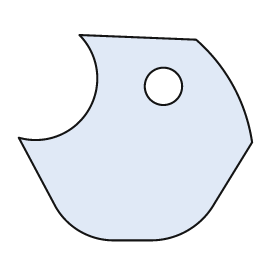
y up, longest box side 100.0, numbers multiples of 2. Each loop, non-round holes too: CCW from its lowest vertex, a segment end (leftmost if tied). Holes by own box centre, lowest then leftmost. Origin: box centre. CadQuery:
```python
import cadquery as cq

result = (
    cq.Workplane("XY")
    .moveTo(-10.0, -44.0)
    .lineTo(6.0, -44.0)
    .threePointArc((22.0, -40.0), (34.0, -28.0))
    .lineTo(50.0, -2.0)
    .threePointArc((42.0, 22.0), (26.0, 42.0))
    .lineTo(-24.0, 44.0)
    .threePointArc((-20.0, 12.0), (-50.0, 0.0))
    .lineTo(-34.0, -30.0)
    .threePointArc((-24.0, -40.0), (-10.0, -44.0))
    .close()
    .moveTo(12.0, 22.0)
    .circle(8.0)
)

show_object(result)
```